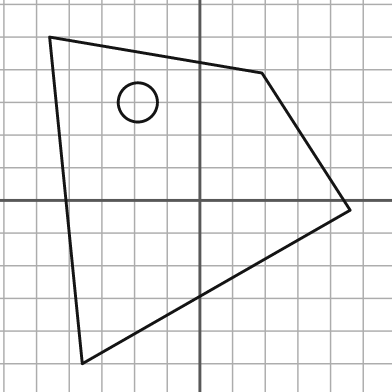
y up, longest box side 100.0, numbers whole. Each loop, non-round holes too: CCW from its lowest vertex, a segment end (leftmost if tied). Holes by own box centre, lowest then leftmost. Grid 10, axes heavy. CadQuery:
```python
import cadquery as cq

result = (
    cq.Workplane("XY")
    .moveTo(-36.0, -50.0)
    .lineTo(46.0, -3.0)
    .lineTo(19.0, 39.0)
    .lineTo(-46.0, 50.0)
    .close()
    .moveTo(-19.0, 30.0)
    .circle(6.0)
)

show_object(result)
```